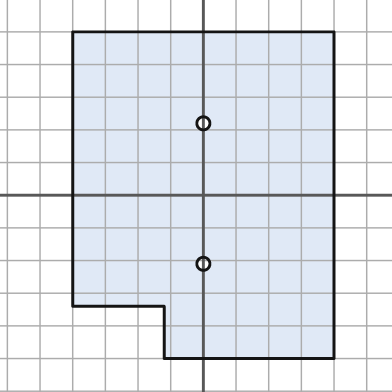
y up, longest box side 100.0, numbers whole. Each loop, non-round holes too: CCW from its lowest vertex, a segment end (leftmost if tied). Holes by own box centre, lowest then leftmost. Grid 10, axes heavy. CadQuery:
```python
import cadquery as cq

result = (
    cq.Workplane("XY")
    .moveTo(-12.0, -50.0)
    .lineTo(40.0, -50.0)
    .lineTo(40.0, 50.0)
    .lineTo(-40.0, 50.0)
    .lineTo(-40.0, -34.0)
    .lineTo(-12.0, -34.0)
    .close()
    .moveTo(0.0, -21.0)
    .circle(2.0)
    .moveTo(0.0, 22.0)
    .circle(2.0)
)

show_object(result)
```